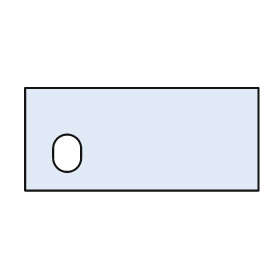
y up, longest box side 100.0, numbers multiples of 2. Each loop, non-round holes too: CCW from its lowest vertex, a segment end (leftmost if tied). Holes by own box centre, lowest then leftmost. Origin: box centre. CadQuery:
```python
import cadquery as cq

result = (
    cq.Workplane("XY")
    .moveTo(-50.0, -22.0)
    .lineTo(50.0, -22.0)
    .lineTo(50.0, 22.0)
    .lineTo(-50.0, 22.0)
    .close()
    .moveTo(-38.0, -8.0)
    .threePointArc((-32.0, -14.0), (-26.0, -8.0))
    .lineTo(-26.0, -4.0)
    .threePointArc((-32.0, 2.0), (-38.0, -4.0))
    .close()
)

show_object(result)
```